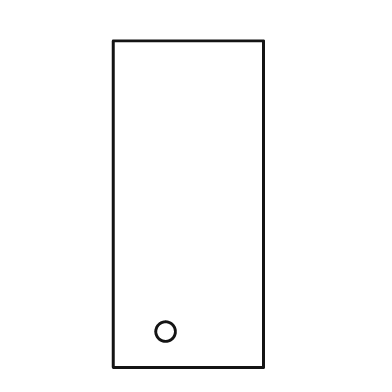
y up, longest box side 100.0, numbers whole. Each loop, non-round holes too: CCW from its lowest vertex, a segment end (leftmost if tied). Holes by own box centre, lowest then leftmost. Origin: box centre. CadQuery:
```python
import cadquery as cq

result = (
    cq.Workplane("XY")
    .moveTo(-23.0, -50.0)
    .lineTo(23.0, -50.0)
    .lineTo(23.0, 50.0)
    .lineTo(-23.0, 50.0)
    .close()
    .moveTo(-7.0, -39.0)
    .circle(3.0)
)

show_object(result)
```